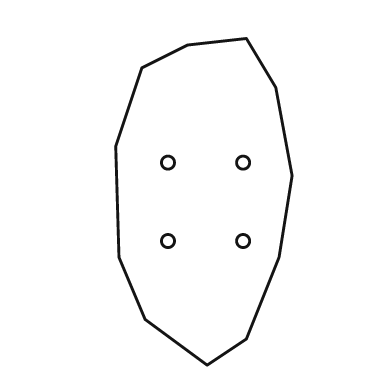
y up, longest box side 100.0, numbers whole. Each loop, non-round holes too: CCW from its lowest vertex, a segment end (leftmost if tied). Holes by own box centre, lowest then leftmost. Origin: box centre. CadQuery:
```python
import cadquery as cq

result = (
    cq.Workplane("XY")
    .moveTo(1.0, -50.0)
    .lineTo(13.0, -42.0)
    .lineTo(23.0, -17.0)
    .lineTo(27.0, 8.0)
    .lineTo(22.0, 35.0)
    .lineTo(13.0, 50.0)
    .lineTo(-5.0, 48.0)
    .lineTo(-19.0, 41.0)
    .lineTo(-27.0, 17.0)
    .lineTo(-26.0, -17.0)
    .lineTo(-18.0, -36.0)
    .close()
    .moveTo(-11.0, -12.0)
    .circle(2.0)
    .moveTo(12.0, -12.0)
    .circle(2.0)
    .moveTo(-11.0, 12.0)
    .circle(2.0)
    .moveTo(12.0, 12.0)
    .circle(2.0)
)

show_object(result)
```